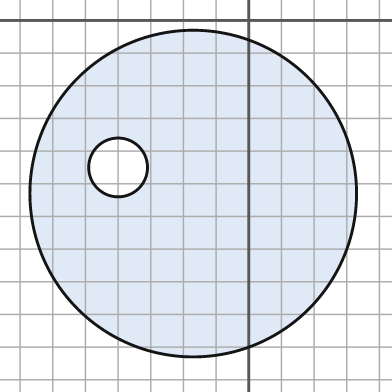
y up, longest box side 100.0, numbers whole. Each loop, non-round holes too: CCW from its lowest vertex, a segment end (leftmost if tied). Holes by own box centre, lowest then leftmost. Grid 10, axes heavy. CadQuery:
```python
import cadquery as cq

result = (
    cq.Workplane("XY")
    .moveTo(-17.0, -53.0)
    .circle(50.0)
    .moveTo(-40.0, -45.0)
    .circle(9.0)
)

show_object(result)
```